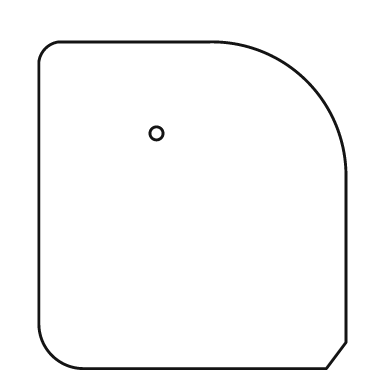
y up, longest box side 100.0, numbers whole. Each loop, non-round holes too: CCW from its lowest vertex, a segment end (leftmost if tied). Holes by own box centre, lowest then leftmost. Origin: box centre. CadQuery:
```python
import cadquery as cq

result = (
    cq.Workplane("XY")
    .moveTo(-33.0, -50.0)
    .lineTo(41.0, -50.0)
    .lineTo(47.0, -42.0)
    .lineTo(47.0, 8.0)
    .threePointArc((35.0, 38.0), (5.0, 50.0))
    .lineTo(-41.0, 50.0)
    .threePointArc((-45.0, 48.0), (-47.0, 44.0))
    .lineTo(-47.0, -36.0)
    .threePointArc((-43.0, -46.0), (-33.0, -50.0))
    .close()
    .moveTo(-11.0, 22.0)
    .circle(2.0)
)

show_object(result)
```